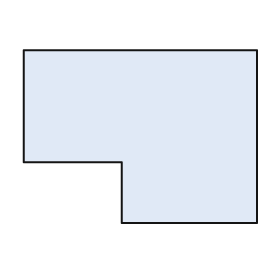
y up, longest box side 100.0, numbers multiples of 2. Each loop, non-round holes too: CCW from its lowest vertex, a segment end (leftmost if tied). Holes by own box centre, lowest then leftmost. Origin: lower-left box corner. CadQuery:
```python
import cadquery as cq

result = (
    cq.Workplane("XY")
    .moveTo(42.0, 0.0)
    .lineTo(100.0, 0.0)
    .lineTo(100.0, 74.0)
    .lineTo(0.0, 74.0)
    .lineTo(0.0, 26.0)
    .lineTo(42.0, 26.0)
    .close()
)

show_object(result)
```